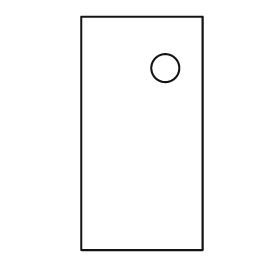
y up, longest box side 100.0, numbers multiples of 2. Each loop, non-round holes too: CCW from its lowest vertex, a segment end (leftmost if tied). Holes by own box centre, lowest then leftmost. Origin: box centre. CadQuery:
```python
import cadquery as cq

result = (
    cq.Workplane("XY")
    .moveTo(-26.0, -50.0)
    .lineTo(26.0, -50.0)
    .lineTo(26.0, 50.0)
    .lineTo(-26.0, 50.0)
    .close()
    .moveTo(10.0, 28.0)
    .circle(6.0)
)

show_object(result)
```